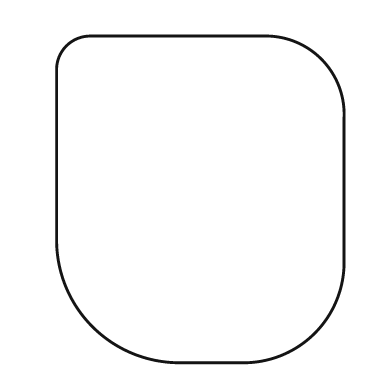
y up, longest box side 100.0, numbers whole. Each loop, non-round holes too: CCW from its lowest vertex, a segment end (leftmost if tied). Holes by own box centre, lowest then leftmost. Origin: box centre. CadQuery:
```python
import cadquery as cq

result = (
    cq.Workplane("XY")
    .moveTo(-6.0, -50.0)
    .lineTo(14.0, -50.0)
    .threePointArc((35.0, -41.0), (44.0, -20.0))
    .lineTo(44.0, 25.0)
    .threePointArc((37.0, 43.0), (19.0, 50.0))
    .lineTo(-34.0, 50.0)
    .threePointArc((-41.0, 47.0), (-44.0, 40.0))
    .lineTo(-44.0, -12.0)
    .threePointArc((-33.0, -39.0), (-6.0, -50.0))
    .close()
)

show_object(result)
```